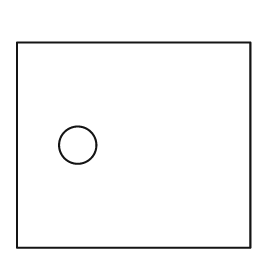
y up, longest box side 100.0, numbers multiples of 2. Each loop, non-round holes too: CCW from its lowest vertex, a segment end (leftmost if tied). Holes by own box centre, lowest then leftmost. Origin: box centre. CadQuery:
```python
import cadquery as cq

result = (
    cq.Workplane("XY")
    .moveTo(-50.0, -44.0)
    .lineTo(50.0, -44.0)
    .lineTo(50.0, 44.0)
    .lineTo(-50.0, 44.0)
    .close()
    .moveTo(-24.0, 0.0)
    .circle(8.0)
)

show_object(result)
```